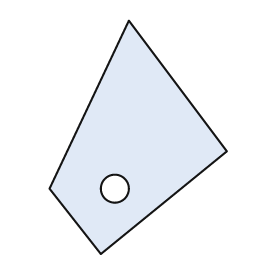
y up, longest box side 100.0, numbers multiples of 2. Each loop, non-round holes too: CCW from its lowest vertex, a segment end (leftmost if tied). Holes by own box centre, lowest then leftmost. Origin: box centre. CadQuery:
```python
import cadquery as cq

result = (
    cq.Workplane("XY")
    .moveTo(-16.0, -50.0)
    .lineTo(38.0, -6.0)
    .lineTo(-4.0, 50.0)
    .lineTo(-38.0, -22.0)
    .close()
    .moveTo(-10.0, -22.0)
    .circle(6.0)
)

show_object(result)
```